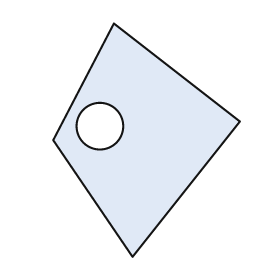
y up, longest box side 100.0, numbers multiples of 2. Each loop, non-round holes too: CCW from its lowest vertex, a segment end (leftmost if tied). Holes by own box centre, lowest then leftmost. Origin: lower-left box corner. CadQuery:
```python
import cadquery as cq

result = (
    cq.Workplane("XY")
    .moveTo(34.0, 0.0)
    .lineTo(80.0, 58.0)
    .lineTo(26.0, 100.0)
    .lineTo(0.0, 50.0)
    .close()
    .moveTo(20.0, 56.0)
    .circle(10.0)
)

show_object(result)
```